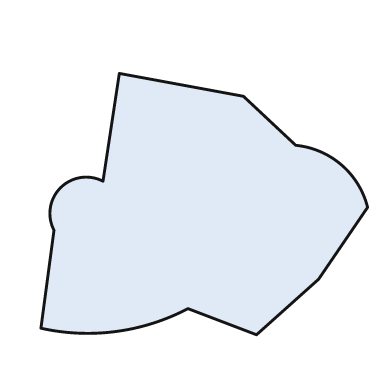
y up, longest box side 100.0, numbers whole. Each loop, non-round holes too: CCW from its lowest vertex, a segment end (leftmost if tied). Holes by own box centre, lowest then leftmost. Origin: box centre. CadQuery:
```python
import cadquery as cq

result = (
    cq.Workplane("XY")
    .moveTo(16.0, -40.0)
    .lineTo(35.0, -23.0)
    .lineTo(50.0, -1.0)
    .threePointArc((42.0, 12.0), (28.0, 18.0))
    .lineTo(12.0, 33.0)
    .lineTo(-26.0, 40.0)
    .lineTo(-31.0, 7.0)
    .threePointArc((-44.0, 5.0), (-46.0, -8.0))
    .lineTo(-50.0, -38.0)
    .threePointArc((-27.0, -39.0), (-5.0, -32.0))
    .close()
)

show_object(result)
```